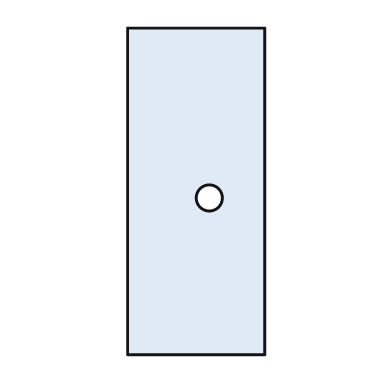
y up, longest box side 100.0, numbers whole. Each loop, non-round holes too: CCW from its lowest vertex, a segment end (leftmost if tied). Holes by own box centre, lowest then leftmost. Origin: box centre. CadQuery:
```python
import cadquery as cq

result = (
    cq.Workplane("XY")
    .moveTo(-21.0, -50.0)
    .lineTo(21.0, -50.0)
    .lineTo(21.0, 50.0)
    .lineTo(-21.0, 50.0)
    .close()
    .moveTo(4.0, -2.0)
    .circle(4.0)
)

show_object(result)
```